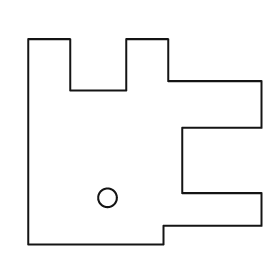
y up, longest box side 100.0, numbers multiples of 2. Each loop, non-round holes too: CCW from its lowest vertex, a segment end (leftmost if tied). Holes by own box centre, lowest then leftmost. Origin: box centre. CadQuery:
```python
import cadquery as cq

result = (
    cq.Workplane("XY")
    .moveTo(-50.0, -44.0)
    .lineTo(8.0, -44.0)
    .lineTo(8.0, -36.0)
    .lineTo(50.0, -36.0)
    .lineTo(50.0, -22.0)
    .lineTo(16.0, -22.0)
    .lineTo(16.0, 6.0)
    .lineTo(50.0, 6.0)
    .lineTo(50.0, 26.0)
    .lineTo(10.0, 26.0)
    .lineTo(10.0, 44.0)
    .lineTo(-8.0, 44.0)
    .lineTo(-8.0, 22.0)
    .lineTo(-32.0, 22.0)
    .lineTo(-32.0, 44.0)
    .lineTo(-50.0, 44.0)
    .close()
    .moveTo(-16.0, -24.0)
    .circle(4.0)
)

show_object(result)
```